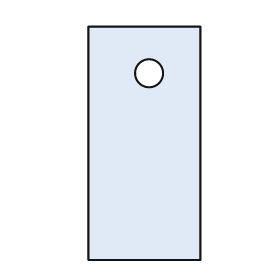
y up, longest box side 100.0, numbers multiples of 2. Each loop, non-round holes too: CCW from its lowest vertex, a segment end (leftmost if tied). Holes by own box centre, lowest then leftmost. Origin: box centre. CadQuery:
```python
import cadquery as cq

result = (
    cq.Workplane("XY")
    .moveTo(-24.0, -50.0)
    .lineTo(24.0, -50.0)
    .lineTo(24.0, 50.0)
    .lineTo(-24.0, 50.0)
    .close()
    .moveTo(2.0, 30.0)
    .circle(6.0)
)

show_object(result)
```